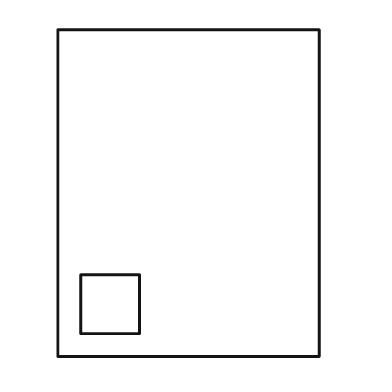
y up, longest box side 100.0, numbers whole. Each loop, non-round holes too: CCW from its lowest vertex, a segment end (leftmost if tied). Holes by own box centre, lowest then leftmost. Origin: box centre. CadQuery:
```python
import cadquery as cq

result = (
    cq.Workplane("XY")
    .moveTo(-40.0, -50.0)
    .lineTo(40.0, -50.0)
    .lineTo(40.0, 50.0)
    .lineTo(-40.0, 50.0)
    .close()
    .moveTo(-33.0, -43.0)
    .lineTo(-15.0, -43.0)
    .lineTo(-15.0, -25.0)
    .lineTo(-33.0, -25.0)
    .close()
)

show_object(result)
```